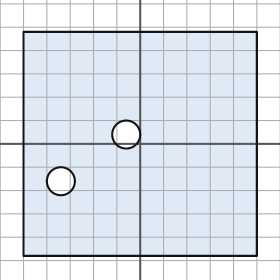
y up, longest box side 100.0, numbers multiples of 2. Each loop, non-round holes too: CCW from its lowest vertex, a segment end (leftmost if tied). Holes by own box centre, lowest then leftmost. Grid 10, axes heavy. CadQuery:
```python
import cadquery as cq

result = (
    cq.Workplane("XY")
    .moveTo(-50.0, -48.0)
    .lineTo(50.0, -48.0)
    .lineTo(50.0, 48.0)
    .lineTo(-50.0, 48.0)
    .close()
    .moveTo(-34.0, -16.0)
    .circle(6.0)
    .moveTo(-6.0, 4.0)
    .circle(6.0)
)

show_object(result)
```